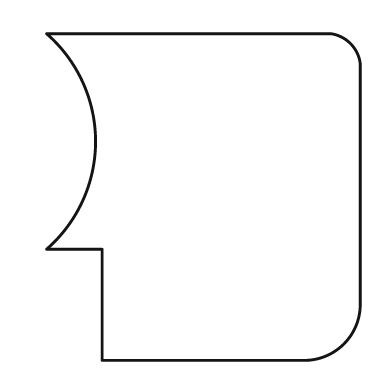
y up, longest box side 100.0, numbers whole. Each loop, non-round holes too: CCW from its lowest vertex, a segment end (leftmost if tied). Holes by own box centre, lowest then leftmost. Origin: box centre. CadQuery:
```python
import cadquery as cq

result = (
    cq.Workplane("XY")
    .moveTo(-31.0, -50.0)
    .lineTo(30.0, -50.0)
    .threePointArc((43.0, -45.0), (48.0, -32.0))
    .lineTo(48.0, 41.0)
    .threePointArc((45.0, 47.0), (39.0, 50.0))
    .lineTo(-48.0, 50.0)
    .threePointArc((-33.0, 17.0), (-48.0, -16.0))
    .lineTo(-31.0, -16.0)
    .close()
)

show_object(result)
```